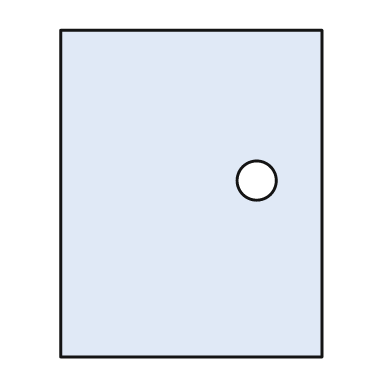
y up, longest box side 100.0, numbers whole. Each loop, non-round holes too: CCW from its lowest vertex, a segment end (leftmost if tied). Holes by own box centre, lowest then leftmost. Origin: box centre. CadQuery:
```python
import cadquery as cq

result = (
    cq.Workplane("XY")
    .moveTo(-40.0, -50.0)
    .lineTo(40.0, -50.0)
    .lineTo(40.0, 50.0)
    .lineTo(-40.0, 50.0)
    .close()
    .moveTo(20.0, 4.0)
    .circle(6.0)
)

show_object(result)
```